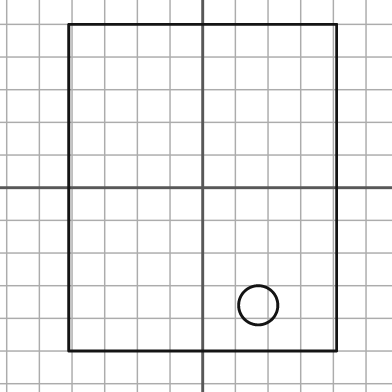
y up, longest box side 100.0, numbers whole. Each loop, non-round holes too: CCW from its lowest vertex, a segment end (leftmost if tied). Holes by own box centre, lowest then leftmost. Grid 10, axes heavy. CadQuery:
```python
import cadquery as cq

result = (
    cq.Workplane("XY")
    .moveTo(-41.0, -50.0)
    .lineTo(41.0, -50.0)
    .lineTo(41.0, 50.0)
    .lineTo(-41.0, 50.0)
    .close()
    .moveTo(17.0, -36.0)
    .circle(6.0)
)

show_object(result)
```